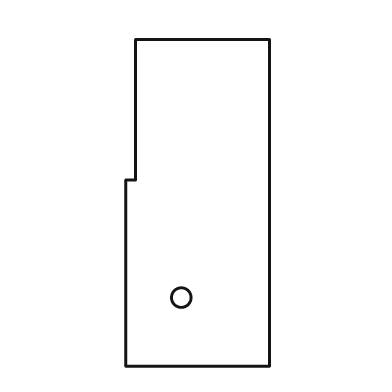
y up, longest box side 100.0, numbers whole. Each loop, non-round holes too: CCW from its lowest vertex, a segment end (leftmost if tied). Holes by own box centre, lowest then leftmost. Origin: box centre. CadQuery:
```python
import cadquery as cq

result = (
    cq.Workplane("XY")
    .moveTo(-22.0, -50.0)
    .lineTo(22.0, -50.0)
    .lineTo(22.0, 50.0)
    .lineTo(-19.0, 50.0)
    .lineTo(-19.0, 7.0)
    .lineTo(-22.0, 7.0)
    .close()
    .moveTo(-5.0, -29.0)
    .circle(3.0)
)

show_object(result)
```